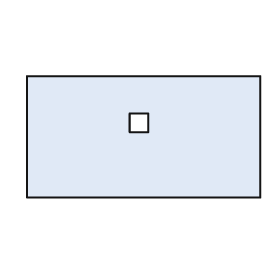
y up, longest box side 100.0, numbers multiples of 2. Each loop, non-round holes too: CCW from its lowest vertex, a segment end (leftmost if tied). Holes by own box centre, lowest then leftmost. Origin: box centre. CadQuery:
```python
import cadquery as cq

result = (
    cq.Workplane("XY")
    .moveTo(-50.0, -26.0)
    .lineTo(50.0, -26.0)
    .lineTo(50.0, 26.0)
    .lineTo(-50.0, 26.0)
    .close()
    .moveTo(-6.0, 2.0)
    .lineTo(2.0, 2.0)
    .lineTo(2.0, 10.0)
    .lineTo(-6.0, 10.0)
    .close()
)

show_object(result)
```